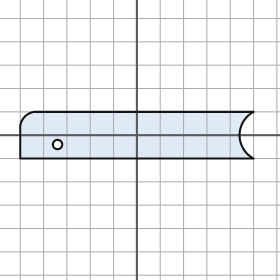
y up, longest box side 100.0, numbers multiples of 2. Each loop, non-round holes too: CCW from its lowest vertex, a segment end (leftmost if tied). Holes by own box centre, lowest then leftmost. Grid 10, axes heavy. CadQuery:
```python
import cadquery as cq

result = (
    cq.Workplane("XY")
    .moveTo(-50.0, -10.0)
    .lineTo(50.0, -10.0)
    .threePointArc((44.0, 0.0), (50.0, 10.0))
    .lineTo(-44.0, 10.0)
    .threePointArc((-48.0, 8.0), (-50.0, 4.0))
    .close()
    .moveTo(-34.0, -4.0)
    .circle(2.0)
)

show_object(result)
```